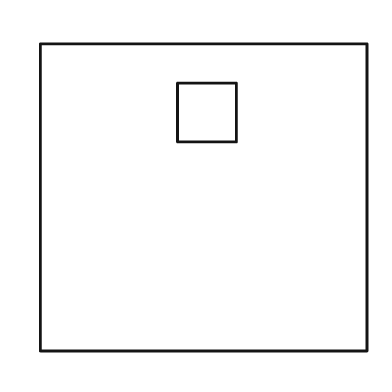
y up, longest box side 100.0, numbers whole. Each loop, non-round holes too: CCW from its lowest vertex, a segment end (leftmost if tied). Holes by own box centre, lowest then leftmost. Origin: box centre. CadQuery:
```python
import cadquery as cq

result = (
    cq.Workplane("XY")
    .moveTo(-50.0, -47.0)
    .lineTo(50.0, -47.0)
    .lineTo(50.0, 47.0)
    .lineTo(-50.0, 47.0)
    .close()
    .moveTo(-8.0, 17.0)
    .lineTo(10.0, 17.0)
    .lineTo(10.0, 35.0)
    .lineTo(-8.0, 35.0)
    .close()
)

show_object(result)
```